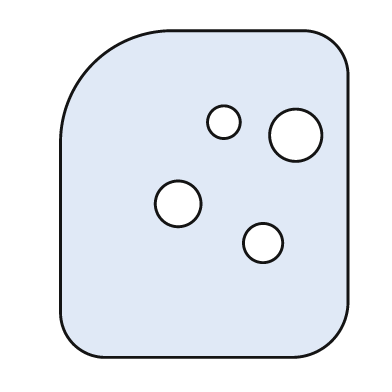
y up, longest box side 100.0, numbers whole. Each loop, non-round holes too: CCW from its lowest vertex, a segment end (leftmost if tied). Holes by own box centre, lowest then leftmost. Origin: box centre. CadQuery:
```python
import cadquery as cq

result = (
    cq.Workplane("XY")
    .moveTo(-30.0, -50.0)
    .lineTo(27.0, -50.0)
    .threePointArc((39.0, -45.0), (44.0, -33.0))
    .lineTo(44.0, 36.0)
    .threePointArc((40.0, 46.0), (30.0, 50.0))
    .lineTo(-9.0, 50.0)
    .threePointArc((-34.0, 40.0), (-44.0, 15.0))
    .lineTo(-44.0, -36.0)
    .threePointArc((-40.0, -46.0), (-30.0, -50.0))
    .close()
    .moveTo(18.0, -15.0)
    .circle(6.0)
    .moveTo(-8.0, -3.0)
    .circle(7.0)
    .moveTo(28.0, 18.0)
    .circle(8.0)
    .moveTo(6.0, 22.0)
    .circle(5.0)
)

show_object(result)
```